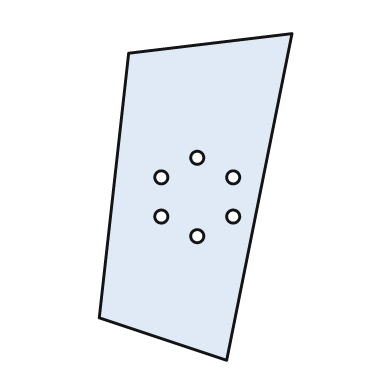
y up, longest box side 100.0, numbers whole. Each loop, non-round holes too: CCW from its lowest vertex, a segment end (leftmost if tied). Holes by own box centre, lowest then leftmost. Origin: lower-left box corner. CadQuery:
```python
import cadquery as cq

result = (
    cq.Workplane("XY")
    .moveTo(39.0, 0.0)
    .lineTo(59.0, 100.0)
    .lineTo(9.0, 94.0)
    .lineTo(0.0, 13.0)
    .close()
    .moveTo(30.0, 38.0)
    .circle(2.0)
    .moveTo(19.0, 44.0)
    .circle(2.0)
    .moveTo(41.0, 44.0)
    .circle(2.0)
    .moveTo(19.0, 56.0)
    .circle(2.0)
    .moveTo(41.0, 56.0)
    .circle(2.0)
    .moveTo(30.0, 62.0)
    .circle(2.0)
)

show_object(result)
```